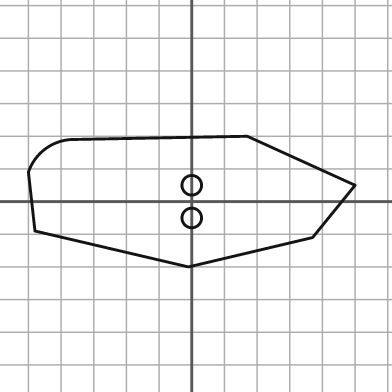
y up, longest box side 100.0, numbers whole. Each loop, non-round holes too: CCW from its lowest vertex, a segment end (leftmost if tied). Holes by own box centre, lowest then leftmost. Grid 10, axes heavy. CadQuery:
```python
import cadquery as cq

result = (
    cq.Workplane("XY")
    .moveTo(-1.0, -20.0)
    .lineTo(37.0, -11.0)
    .lineTo(50.0, 5.0)
    .lineTo(17.0, 20.0)
    .lineTo(-37.0, 19.0)
    .threePointArc((-45.0, 16.0), (-50.0, 9.0))
    .lineTo(-48.0, -9.0)
    .close()
    .moveTo(0.0, -5.0)
    .circle(3.0)
    .moveTo(0.0, 5.0)
    .circle(3.0)
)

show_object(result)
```